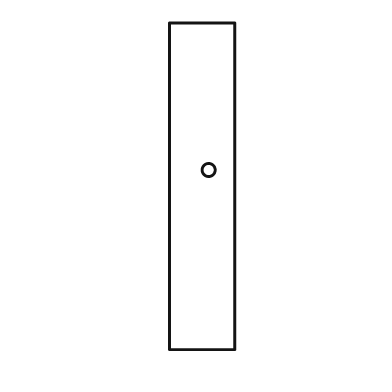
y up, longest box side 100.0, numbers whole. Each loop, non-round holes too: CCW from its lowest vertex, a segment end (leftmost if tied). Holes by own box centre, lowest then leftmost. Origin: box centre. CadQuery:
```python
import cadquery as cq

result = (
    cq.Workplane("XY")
    .moveTo(-10.0, -50.0)
    .lineTo(10.0, -50.0)
    .lineTo(10.0, 50.0)
    .lineTo(-10.0, 50.0)
    .close()
    .moveTo(2.0, 5.0)
    .circle(2.0)
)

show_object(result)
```